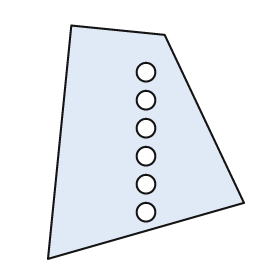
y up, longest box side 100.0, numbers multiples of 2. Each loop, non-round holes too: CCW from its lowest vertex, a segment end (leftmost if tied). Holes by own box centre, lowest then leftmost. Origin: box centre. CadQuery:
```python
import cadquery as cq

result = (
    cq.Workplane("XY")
    .moveTo(-42.0, -50.0)
    .lineTo(42.0, -26.0)
    .lineTo(8.0, 46.0)
    .lineTo(-32.0, 50.0)
    .close()
    .moveTo(0.0, -30.0)
    .circle(4.0)
    .moveTo(0.0, -18.0)
    .circle(4.0)
    .moveTo(0.0, -6.0)
    .circle(4.0)
    .moveTo(0.0, 6.0)
    .circle(4.0)
    .moveTo(0.0, 18.0)
    .circle(4.0)
    .moveTo(0.0, 30.0)
    .circle(4.0)
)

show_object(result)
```